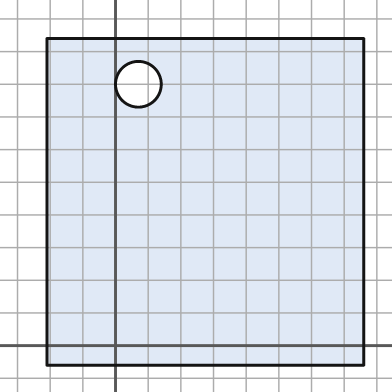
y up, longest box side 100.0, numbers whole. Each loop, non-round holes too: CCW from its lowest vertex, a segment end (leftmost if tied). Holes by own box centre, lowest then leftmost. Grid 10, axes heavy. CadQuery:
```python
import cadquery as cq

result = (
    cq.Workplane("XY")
    .moveTo(-21.0, -6.0)
    .lineTo(76.0, -6.0)
    .lineTo(76.0, 94.0)
    .lineTo(-21.0, 94.0)
    .close()
    .moveTo(7.0, 80.0)
    .circle(7.0)
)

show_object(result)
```